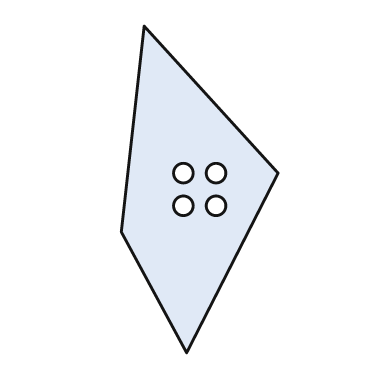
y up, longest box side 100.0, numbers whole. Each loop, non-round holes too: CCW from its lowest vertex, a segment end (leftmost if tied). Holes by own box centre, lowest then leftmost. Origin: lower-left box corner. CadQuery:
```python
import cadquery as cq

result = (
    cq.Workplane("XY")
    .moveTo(20.0, 0.0)
    .lineTo(48.0, 55.0)
    .lineTo(7.0, 100.0)
    .lineTo(0.0, 37.0)
    .close()
    .moveTo(19.0, 45.0)
    .circle(3.0)
    .moveTo(29.0, 45.0)
    .circle(3.0)
    .moveTo(19.0, 55.0)
    .circle(3.0)
    .moveTo(29.0, 55.0)
    .circle(3.0)
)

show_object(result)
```